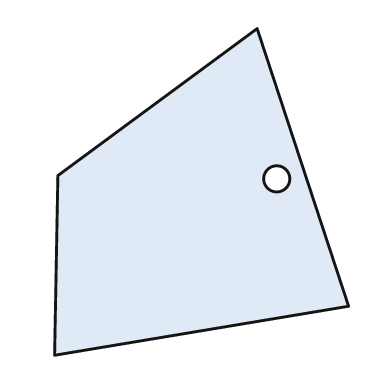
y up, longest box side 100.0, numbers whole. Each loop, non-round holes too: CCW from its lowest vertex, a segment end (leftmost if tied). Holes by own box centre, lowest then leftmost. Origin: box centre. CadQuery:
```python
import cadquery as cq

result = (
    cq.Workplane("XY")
    .moveTo(-45.0, -50.0)
    .lineTo(45.0, -35.0)
    .lineTo(17.0, 50.0)
    .lineTo(-44.0, 5.0)
    .close()
    .moveTo(23.0, 4.0)
    .circle(4.0)
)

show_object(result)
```